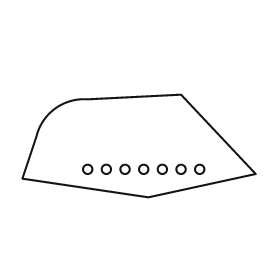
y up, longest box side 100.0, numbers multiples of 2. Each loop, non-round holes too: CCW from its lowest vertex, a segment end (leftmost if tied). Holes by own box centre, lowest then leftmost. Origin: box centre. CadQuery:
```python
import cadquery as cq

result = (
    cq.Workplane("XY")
    .moveTo(4.0, -22.0)
    .lineTo(50.0, -12.0)
    .lineTo(18.0, 22.0)
    .lineTo(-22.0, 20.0)
    .threePointArc((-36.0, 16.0), (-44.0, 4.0))
    .lineTo(-50.0, -14.0)
    .close()
    .moveTo(-22.0, -10.0)
    .circle(2.0)
    .moveTo(-14.0, -10.0)
    .circle(2.0)
    .moveTo(-6.0, -10.0)
    .circle(2.0)
    .moveTo(2.0, -10.0)
    .circle(2.0)
    .moveTo(10.0, -10.0)
    .circle(2.0)
    .moveTo(18.0, -10.0)
    .circle(2.0)
    .moveTo(26.0, -10.0)
    .circle(2.0)
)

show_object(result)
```